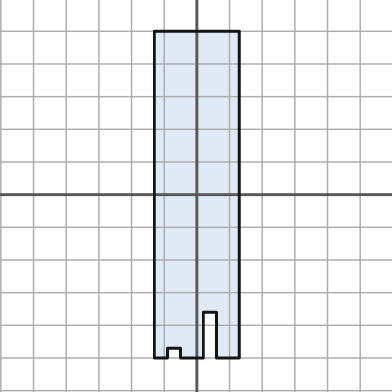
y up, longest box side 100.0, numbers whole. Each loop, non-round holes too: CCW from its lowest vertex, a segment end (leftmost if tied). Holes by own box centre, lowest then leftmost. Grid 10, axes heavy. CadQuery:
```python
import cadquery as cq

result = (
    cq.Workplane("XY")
    .moveTo(-13.0, -50.0)
    .lineTo(-9.0, -50.0)
    .lineTo(-9.0, -47.0)
    .lineTo(-5.0, -47.0)
    .lineTo(-5.0, -50.0)
    .lineTo(2.0, -50.0)
    .lineTo(2.0, -36.0)
    .lineTo(6.0, -36.0)
    .lineTo(6.0, -50.0)
    .lineTo(13.0, -50.0)
    .lineTo(13.0, 50.0)
    .lineTo(-13.0, 50.0)
    .close()
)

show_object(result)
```